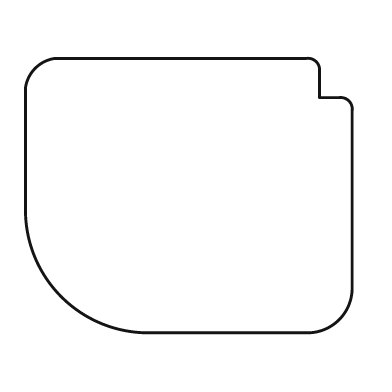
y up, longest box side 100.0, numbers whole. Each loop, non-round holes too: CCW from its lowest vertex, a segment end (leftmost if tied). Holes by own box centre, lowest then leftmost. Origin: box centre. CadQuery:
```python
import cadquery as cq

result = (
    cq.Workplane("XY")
    .moveTo(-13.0, -42.0)
    .lineTo(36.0, -42.0)
    .threePointArc((46.0, -38.0), (50.0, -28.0))
    .lineTo(50.0, 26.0)
    .threePointArc((49.0, 29.0), (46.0, 30.0))
    .lineTo(40.0, 30.0)
    .lineTo(40.0, 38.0)
    .threePointArc((39.0, 41.0), (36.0, 42.0))
    .lineTo(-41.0, 42.0)
    .threePointArc((-47.0, 39.0), (-50.0, 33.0))
    .lineTo(-50.0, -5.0)
    .threePointArc((-39.0, -31.0), (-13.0, -42.0))
    .close()
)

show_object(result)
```